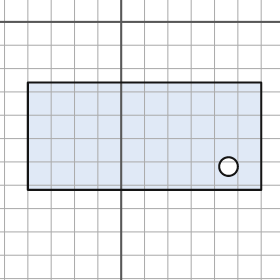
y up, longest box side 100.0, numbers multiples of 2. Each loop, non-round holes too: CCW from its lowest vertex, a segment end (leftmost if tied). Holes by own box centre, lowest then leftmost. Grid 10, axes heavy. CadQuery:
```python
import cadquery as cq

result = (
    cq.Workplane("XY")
    .moveTo(-40.0, -72.0)
    .lineTo(60.0, -72.0)
    .lineTo(60.0, -26.0)
    .lineTo(-40.0, -26.0)
    .close()
    .moveTo(46.0, -62.0)
    .circle(4.0)
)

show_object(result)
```